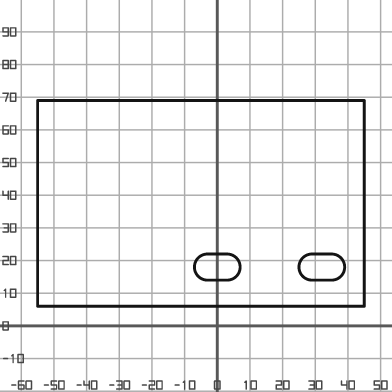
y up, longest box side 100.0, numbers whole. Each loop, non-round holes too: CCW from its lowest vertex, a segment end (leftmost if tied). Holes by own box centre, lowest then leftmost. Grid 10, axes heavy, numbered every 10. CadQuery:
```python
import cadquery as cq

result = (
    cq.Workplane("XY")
    .moveTo(-55.0, 6.0)
    .lineTo(45.0, 6.0)
    .lineTo(45.0, 69.0)
    .lineTo(-55.0, 69.0)
    .close()
    .moveTo(-3.0, 14.0)
    .lineTo(3.0, 14.0)
    .threePointArc((7.0, 18.0), (3.0, 22.0))
    .lineTo(-3.0, 22.0)
    .threePointArc((-7.0, 18.0), (-3.0, 14.0))
    .close()
    .moveTo(29.0, 14.0)
    .lineTo(35.0, 14.0)
    .threePointArc((39.0, 18.0), (35.0, 22.0))
    .lineTo(29.0, 22.0)
    .threePointArc((25.0, 18.0), (29.0, 14.0))
    .close()
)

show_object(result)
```